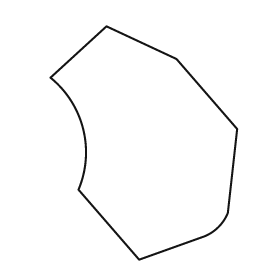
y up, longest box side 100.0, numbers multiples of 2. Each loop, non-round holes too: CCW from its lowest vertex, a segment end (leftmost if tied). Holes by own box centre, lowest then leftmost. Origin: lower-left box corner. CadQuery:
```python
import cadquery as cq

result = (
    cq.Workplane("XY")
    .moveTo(38.0, 0.0)
    .lineTo(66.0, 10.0)
    .threePointArc((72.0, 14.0), (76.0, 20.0))
    .lineTo(80.0, 56.0)
    .lineTo(54.0, 86.0)
    .lineTo(24.0, 100.0)
    .lineTo(0.0, 78.0)
    .threePointArc((14.0, 56.0), (12.0, 30.0))
    .close()
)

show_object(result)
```